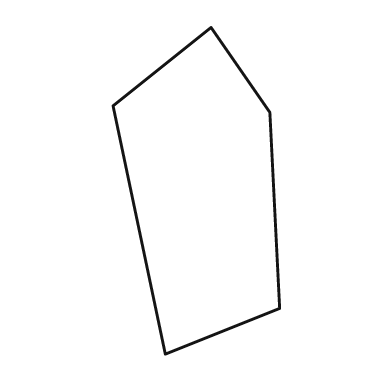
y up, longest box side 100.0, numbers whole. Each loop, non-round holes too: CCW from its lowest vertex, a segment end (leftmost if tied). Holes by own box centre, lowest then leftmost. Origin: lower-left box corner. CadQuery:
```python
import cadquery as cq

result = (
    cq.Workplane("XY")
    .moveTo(16.0, 0.0)
    .lineTo(51.0, 14.0)
    .lineTo(48.0, 74.0)
    .lineTo(30.0, 100.0)
    .lineTo(0.0, 76.0)
    .close()
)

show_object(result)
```